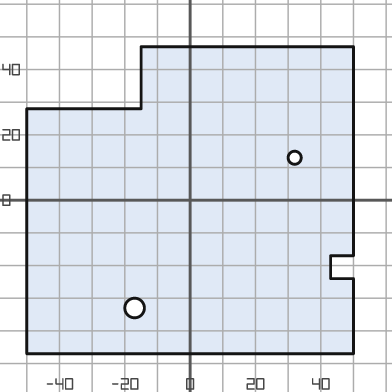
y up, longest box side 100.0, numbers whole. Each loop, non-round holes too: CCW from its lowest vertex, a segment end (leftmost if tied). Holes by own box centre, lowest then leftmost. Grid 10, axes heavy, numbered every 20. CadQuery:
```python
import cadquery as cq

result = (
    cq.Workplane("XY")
    .moveTo(-50.0, -47.0)
    .lineTo(50.0, -47.0)
    .lineTo(50.0, -24.0)
    .lineTo(43.0, -24.0)
    .lineTo(43.0, -17.0)
    .lineTo(50.0, -17.0)
    .lineTo(50.0, 47.0)
    .lineTo(-15.0, 47.0)
    .lineTo(-15.0, 28.0)
    .lineTo(-50.0, 28.0)
    .close()
    .moveTo(-17.0, -33.0)
    .circle(3.0)
    .moveTo(32.0, 13.0)
    .circle(2.0)
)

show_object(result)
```